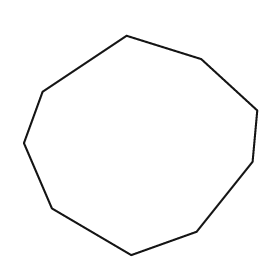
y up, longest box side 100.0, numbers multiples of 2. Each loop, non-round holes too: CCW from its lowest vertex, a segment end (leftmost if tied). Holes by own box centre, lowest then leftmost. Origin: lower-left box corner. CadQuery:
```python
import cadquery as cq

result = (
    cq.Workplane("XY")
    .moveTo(46.0, 0.0)
    .lineTo(74.0, 10.0)
    .lineTo(98.0, 40.0)
    .lineTo(100.0, 62.0)
    .lineTo(76.0, 84.0)
    .lineTo(44.0, 94.0)
    .lineTo(8.0, 70.0)
    .lineTo(0.0, 48.0)
    .lineTo(12.0, 20.0)
    .close()
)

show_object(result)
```